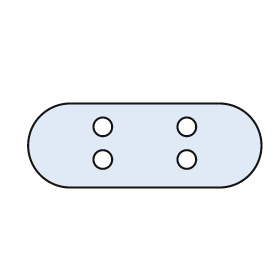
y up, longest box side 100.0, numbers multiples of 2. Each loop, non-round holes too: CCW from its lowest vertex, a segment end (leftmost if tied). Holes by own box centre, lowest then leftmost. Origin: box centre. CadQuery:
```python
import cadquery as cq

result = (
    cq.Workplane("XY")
    .moveTo(-32.0, -18.0)
    .lineTo(32.0, -18.0)
    .threePointArc((50.0, 0.0), (32.0, 18.0))
    .lineTo(-32.0, 18.0)
    .threePointArc((-50.0, 0.0), (-32.0, -18.0))
    .close()
    .moveTo(-18.0, -6.0)
    .circle(4.0)
    .moveTo(18.0, -6.0)
    .circle(4.0)
    .moveTo(-18.0, 8.0)
    .circle(4.0)
    .moveTo(18.0, 8.0)
    .circle(4.0)
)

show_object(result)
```